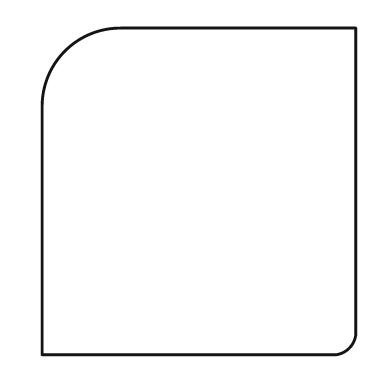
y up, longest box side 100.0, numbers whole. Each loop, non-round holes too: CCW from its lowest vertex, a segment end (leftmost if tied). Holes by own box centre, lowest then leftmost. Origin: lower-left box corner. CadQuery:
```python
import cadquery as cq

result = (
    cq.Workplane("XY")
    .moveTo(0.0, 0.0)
    .lineTo(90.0, 0.0)
    .threePointArc((94.0, 2.0), (96.0, 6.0))
    .lineTo(96.0, 100.0)
    .lineTo(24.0, 100.0)
    .threePointArc((7.0, 93.0), (0.0, 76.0))
    .close()
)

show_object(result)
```